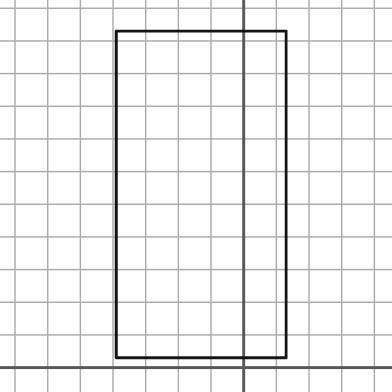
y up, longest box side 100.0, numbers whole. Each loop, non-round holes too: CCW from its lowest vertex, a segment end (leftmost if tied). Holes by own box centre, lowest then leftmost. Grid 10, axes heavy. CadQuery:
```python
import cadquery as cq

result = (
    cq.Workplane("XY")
    .moveTo(-39.0, 3.0)
    .lineTo(13.0, 3.0)
    .lineTo(13.0, 103.0)
    .lineTo(-39.0, 103.0)
    .close()
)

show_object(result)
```